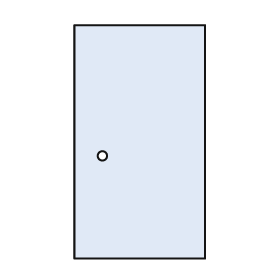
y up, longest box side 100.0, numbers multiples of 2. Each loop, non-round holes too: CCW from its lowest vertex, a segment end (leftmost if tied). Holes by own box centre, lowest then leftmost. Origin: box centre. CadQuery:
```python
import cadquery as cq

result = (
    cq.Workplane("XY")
    .moveTo(-28.0, -50.0)
    .lineTo(28.0, -50.0)
    .lineTo(28.0, 50.0)
    .lineTo(-28.0, 50.0)
    .close()
    .moveTo(-16.0, -6.0)
    .circle(2.0)
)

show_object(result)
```